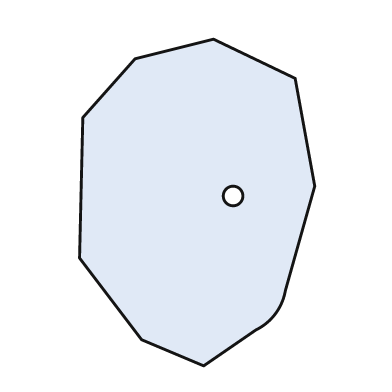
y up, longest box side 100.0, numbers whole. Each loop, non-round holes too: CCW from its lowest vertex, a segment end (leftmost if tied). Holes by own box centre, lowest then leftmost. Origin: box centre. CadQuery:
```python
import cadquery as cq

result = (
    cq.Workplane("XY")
    .moveTo(2.0, -50.0)
    .lineTo(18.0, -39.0)
    .threePointArc((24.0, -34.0), (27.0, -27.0))
    .lineTo(36.0, 5.0)
    .lineTo(30.0, 38.0)
    .lineTo(5.0, 50.0)
    .lineTo(-19.0, 44.0)
    .lineTo(-35.0, 26.0)
    .lineTo(-36.0, -17.0)
    .lineTo(-17.0, -42.0)
    .close()
    .moveTo(11.0, 2.0)
    .circle(3.0)
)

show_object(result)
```